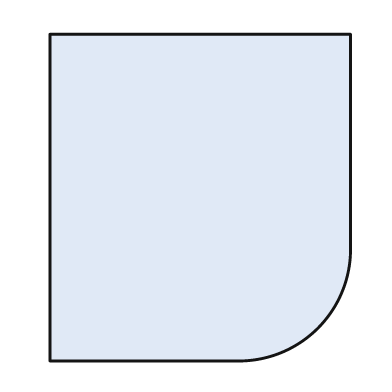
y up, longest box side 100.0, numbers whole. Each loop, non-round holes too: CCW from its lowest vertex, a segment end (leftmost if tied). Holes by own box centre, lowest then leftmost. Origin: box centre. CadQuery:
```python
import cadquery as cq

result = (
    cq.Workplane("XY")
    .moveTo(-46.0, -50.0)
    .lineTo(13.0, -50.0)
    .threePointArc((36.0, -40.0), (46.0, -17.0))
    .lineTo(46.0, 50.0)
    .lineTo(-46.0, 50.0)
    .close()
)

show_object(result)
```